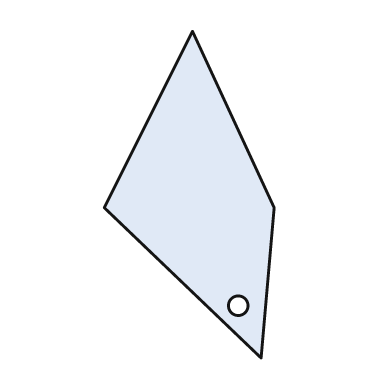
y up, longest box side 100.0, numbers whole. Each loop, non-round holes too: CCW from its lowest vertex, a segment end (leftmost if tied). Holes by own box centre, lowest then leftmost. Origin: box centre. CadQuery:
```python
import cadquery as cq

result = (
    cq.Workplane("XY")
    .moveTo(22.0, -50.0)
    .lineTo(26.0, -4.0)
    .lineTo(1.0, 50.0)
    .lineTo(-26.0, -4.0)
    .close()
    .moveTo(15.0, -34.0)
    .circle(3.0)
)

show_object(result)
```